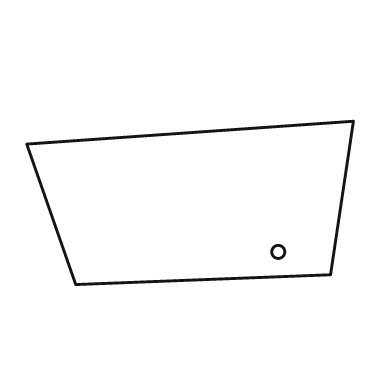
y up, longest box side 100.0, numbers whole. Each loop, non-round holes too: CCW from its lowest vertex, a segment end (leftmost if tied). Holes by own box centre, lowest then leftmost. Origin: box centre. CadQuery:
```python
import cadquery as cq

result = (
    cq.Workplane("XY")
    .moveTo(-35.0, -25.0)
    .lineTo(43.0, -22.0)
    .lineTo(50.0, 25.0)
    .lineTo(-50.0, 18.0)
    .close()
    .moveTo(27.0, -15.0)
    .circle(2.0)
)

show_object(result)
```